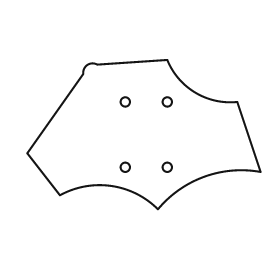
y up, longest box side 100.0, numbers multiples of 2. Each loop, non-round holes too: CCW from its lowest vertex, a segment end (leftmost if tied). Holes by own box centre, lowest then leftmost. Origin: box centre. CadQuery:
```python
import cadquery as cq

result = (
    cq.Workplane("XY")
    .moveTo(6.0, -32.0)
    .threePointArc((26.0, -18.0), (50.0, -16.0))
    .lineTo(40.0, 14.0)
    .threePointArc((22.0, 18.0), (10.0, 32.0))
    .lineTo(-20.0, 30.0)
    .threePointArc((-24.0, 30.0), (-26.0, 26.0))
    .lineTo(-50.0, -8.0)
    .lineTo(-36.0, -26.0)
    .threePointArc((-14.0, -22.0), (6.0, -32.0))
    .close()
    .moveTo(-8.0, -14.0)
    .circle(2.0)
    .moveTo(10.0, -14.0)
    .circle(2.0)
    .moveTo(-8.0, 14.0)
    .circle(2.0)
    .moveTo(10.0, 14.0)
    .circle(2.0)
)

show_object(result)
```